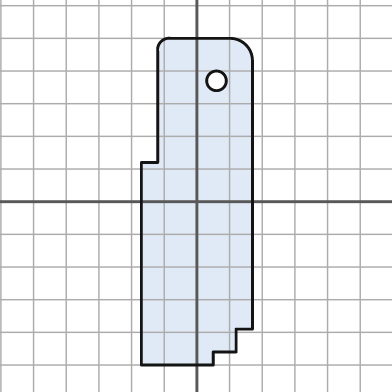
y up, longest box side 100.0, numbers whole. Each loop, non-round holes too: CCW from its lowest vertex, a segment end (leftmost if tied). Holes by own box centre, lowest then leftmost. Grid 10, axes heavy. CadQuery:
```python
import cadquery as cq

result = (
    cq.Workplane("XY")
    .moveTo(-17.0, -50.0)
    .lineTo(5.0, -50.0)
    .lineTo(5.0, -46.0)
    .lineTo(12.0, -46.0)
    .lineTo(12.0, -39.0)
    .lineTo(17.0, -39.0)
    .lineTo(17.0, 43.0)
    .threePointArc((15.0, 48.0), (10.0, 50.0))
    .lineTo(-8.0, 50.0)
    .threePointArc((-11.0, 49.0), (-12.0, 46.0))
    .lineTo(-12.0, 12.0)
    .lineTo(-17.0, 12.0)
    .close()
    .moveTo(6.0, 37.0)
    .circle(3.0)
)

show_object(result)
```